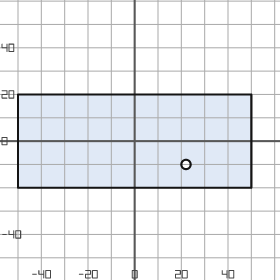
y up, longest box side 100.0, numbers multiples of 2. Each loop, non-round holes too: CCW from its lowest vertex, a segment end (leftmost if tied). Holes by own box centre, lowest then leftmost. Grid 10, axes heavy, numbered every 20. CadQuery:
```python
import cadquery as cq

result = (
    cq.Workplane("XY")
    .moveTo(-50.0, -20.0)
    .lineTo(50.0, -20.0)
    .lineTo(50.0, 20.0)
    .lineTo(-50.0, 20.0)
    .close()
    .moveTo(22.0, -10.0)
    .circle(2.0)
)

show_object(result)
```